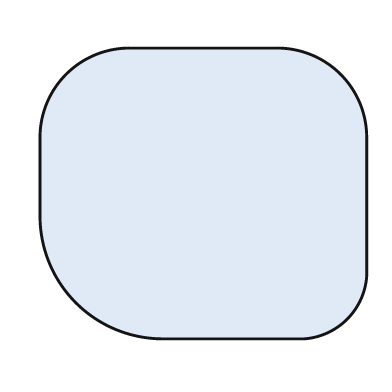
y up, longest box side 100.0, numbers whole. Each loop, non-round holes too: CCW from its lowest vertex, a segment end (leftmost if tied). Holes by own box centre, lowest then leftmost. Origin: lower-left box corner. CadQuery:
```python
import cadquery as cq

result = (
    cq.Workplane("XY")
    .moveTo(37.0, 0.0)
    .lineTo(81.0, 0.0)
    .threePointArc((94.0, 6.0), (100.0, 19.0))
    .lineTo(100.0, 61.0)
    .threePointArc((92.0, 81.0), (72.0, 89.0))
    .lineTo(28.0, 89.0)
    .threePointArc((8.0, 81.0), (0.0, 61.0))
    .lineTo(0.0, 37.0)
    .threePointArc((11.0, 11.0), (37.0, 0.0))
    .close()
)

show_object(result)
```